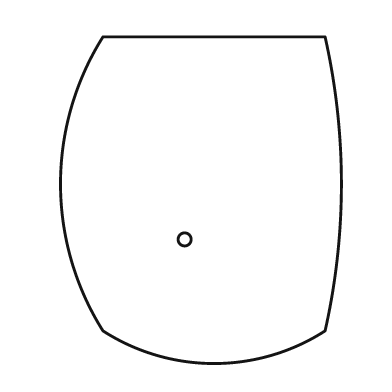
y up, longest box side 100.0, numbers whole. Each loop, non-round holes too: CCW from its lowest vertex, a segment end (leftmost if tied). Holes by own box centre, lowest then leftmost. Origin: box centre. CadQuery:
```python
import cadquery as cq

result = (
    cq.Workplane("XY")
    .moveTo(-30.0, -40.0)
    .threePointArc((4.0, -50.0), (38.0, -40.0))
    .threePointArc((43.0, 5.0), (38.0, 50.0))
    .lineTo(-30.0, 50.0)
    .threePointArc((-43.0, 5.0), (-30.0, -40.0))
    .close()
    .moveTo(-5.0, -12.0)
    .circle(2.0)
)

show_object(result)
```